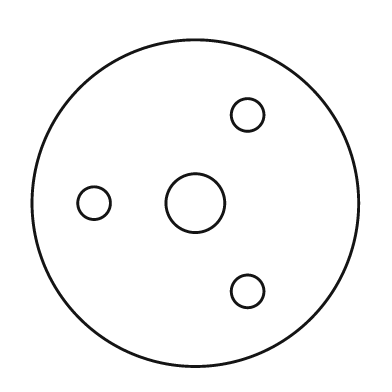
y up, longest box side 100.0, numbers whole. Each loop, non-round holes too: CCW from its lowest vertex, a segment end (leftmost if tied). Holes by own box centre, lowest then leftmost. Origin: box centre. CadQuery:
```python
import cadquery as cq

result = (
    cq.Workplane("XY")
    .moveTo(0.0, 0.0)
    .circle(50.0)
    .moveTo(16.0, -27.0)
    .circle(5.0)
    .moveTo(-31.0, 0.0)
    .circle(5.0)
    .moveTo(0.0, 0.0)
    .circle(9.0)
    .moveTo(16.0, 27.0)
    .circle(5.0)
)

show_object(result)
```